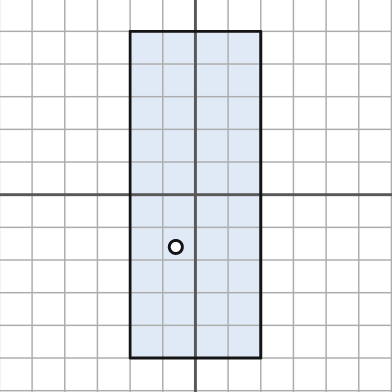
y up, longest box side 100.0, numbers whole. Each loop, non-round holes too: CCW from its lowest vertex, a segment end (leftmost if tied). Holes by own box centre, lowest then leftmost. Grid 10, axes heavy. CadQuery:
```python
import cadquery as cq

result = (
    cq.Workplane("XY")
    .moveTo(-20.0, -50.0)
    .lineTo(20.0, -50.0)
    .lineTo(20.0, 50.0)
    .lineTo(-20.0, 50.0)
    .close()
    .moveTo(-6.0, -16.0)
    .circle(2.0)
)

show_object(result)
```